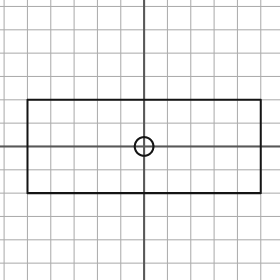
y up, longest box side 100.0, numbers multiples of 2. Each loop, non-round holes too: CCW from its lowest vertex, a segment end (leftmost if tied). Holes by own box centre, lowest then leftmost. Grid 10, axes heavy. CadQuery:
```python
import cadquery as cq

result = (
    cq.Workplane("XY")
    .moveTo(-50.0, -20.0)
    .lineTo(50.0, -20.0)
    .lineTo(50.0, 20.0)
    .lineTo(-50.0, 20.0)
    .close()
    .moveTo(0.0, 0.0)
    .circle(4.0)
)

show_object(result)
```